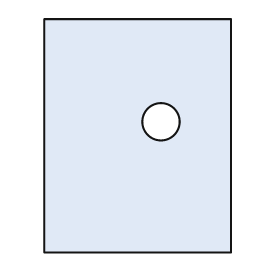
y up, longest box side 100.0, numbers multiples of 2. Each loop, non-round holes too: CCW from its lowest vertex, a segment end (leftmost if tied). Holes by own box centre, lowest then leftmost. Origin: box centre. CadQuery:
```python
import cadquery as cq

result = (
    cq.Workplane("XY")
    .moveTo(-40.0, -50.0)
    .lineTo(40.0, -50.0)
    .lineTo(40.0, 50.0)
    .lineTo(-40.0, 50.0)
    .close()
    .moveTo(10.0, 6.0)
    .circle(8.0)
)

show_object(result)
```